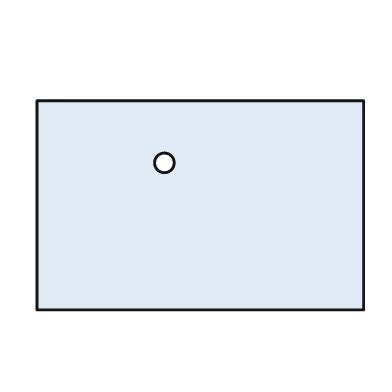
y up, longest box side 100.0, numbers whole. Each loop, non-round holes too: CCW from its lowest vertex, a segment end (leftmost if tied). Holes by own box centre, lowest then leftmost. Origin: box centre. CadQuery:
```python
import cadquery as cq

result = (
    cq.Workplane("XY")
    .moveTo(-50.0, -32.0)
    .lineTo(50.0, -32.0)
    .lineTo(50.0, 32.0)
    .lineTo(-50.0, 32.0)
    .close()
    .moveTo(-11.0, 13.0)
    .circle(3.0)
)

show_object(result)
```